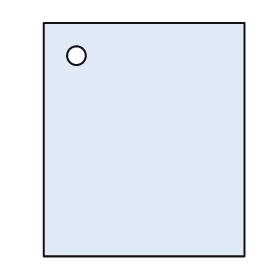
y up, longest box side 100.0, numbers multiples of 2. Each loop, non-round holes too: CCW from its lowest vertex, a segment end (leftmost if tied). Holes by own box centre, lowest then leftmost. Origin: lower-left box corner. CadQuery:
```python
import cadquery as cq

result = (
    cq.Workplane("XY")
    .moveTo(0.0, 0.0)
    .lineTo(86.0, 0.0)
    .lineTo(86.0, 100.0)
    .lineTo(0.0, 100.0)
    .close()
    .moveTo(14.0, 86.0)
    .circle(4.0)
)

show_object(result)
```